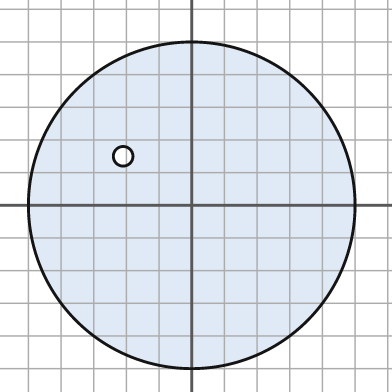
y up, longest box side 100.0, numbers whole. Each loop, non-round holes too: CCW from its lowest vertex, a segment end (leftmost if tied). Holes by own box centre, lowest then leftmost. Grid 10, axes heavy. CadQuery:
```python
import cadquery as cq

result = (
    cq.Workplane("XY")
    .moveTo(0.0, 0.0)
    .circle(50.0)
    .moveTo(-21.0, 15.0)
    .circle(3.0)
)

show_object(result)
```